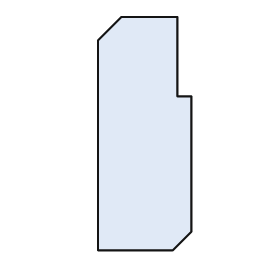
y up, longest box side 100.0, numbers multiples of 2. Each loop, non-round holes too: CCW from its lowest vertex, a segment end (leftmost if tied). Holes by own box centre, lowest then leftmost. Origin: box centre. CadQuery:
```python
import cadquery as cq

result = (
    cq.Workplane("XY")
    .moveTo(-20.0, -50.0)
    .lineTo(12.0, -50.0)
    .lineTo(20.0, -42.0)
    .lineTo(20.0, 16.0)
    .lineTo(14.0, 16.0)
    .lineTo(14.0, 50.0)
    .lineTo(-10.0, 50.0)
    .lineTo(-20.0, 40.0)
    .close()
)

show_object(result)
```